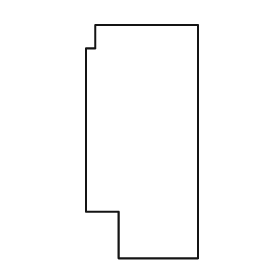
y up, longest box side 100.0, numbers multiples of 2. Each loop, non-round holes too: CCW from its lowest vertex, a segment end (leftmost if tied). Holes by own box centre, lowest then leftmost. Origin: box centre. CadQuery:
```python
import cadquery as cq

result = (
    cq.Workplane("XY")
    .moveTo(-10.0, -50.0)
    .lineTo(24.0, -50.0)
    .lineTo(24.0, 50.0)
    .lineTo(-20.0, 50.0)
    .lineTo(-20.0, 40.0)
    .lineTo(-24.0, 40.0)
    .lineTo(-24.0, -30.0)
    .lineTo(-10.0, -30.0)
    .close()
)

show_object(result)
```